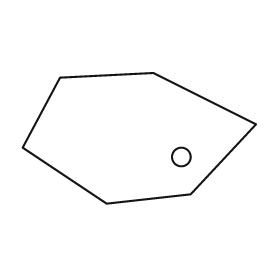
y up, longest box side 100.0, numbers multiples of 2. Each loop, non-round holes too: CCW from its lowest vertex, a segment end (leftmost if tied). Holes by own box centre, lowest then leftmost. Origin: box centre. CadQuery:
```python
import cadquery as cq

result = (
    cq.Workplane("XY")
    .moveTo(-14.0, -28.0)
    .lineTo(22.0, -24.0)
    .lineTo(50.0, 6.0)
    .lineTo(6.0, 28.0)
    .lineTo(-34.0, 26.0)
    .lineTo(-50.0, -4.0)
    .close()
    .moveTo(18.0, -8.0)
    .circle(4.0)
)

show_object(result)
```